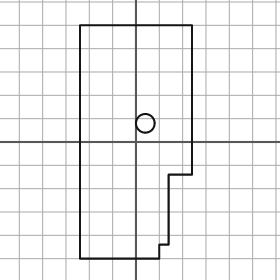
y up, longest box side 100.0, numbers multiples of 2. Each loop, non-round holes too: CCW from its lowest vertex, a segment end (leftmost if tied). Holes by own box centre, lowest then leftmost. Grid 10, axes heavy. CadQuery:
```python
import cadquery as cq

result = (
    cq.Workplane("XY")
    .moveTo(-24.0, -50.0)
    .lineTo(10.0, -50.0)
    .lineTo(10.0, -44.0)
    .lineTo(14.0, -44.0)
    .lineTo(14.0, -14.0)
    .lineTo(24.0, -14.0)
    .lineTo(24.0, 50.0)
    .lineTo(-24.0, 50.0)
    .close()
    .moveTo(4.0, 8.0)
    .circle(4.0)
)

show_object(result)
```